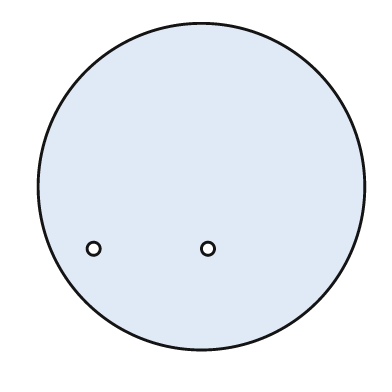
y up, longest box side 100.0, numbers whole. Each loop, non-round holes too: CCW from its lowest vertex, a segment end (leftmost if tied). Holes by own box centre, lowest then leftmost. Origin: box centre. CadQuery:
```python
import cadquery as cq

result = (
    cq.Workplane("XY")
    .moveTo(0.0, 0.0)
    .circle(50.0)
    .moveTo(-33.0, -19.0)
    .circle(2.0)
    .moveTo(2.0, -19.0)
    .circle(2.0)
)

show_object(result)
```